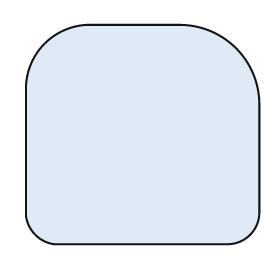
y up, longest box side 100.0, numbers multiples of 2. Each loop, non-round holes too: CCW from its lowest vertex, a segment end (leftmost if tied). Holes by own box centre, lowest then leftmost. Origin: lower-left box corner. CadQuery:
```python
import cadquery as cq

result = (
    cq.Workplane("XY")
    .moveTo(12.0, 0.0)
    .lineTo(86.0, 0.0)
    .threePointArc((96.0, 4.0), (100.0, 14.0))
    .lineTo(100.0, 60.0)
    .threePointArc((90.0, 84.0), (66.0, 94.0))
    .lineTo(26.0, 94.0)
    .threePointArc((8.0, 86.0), (0.0, 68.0))
    .lineTo(0.0, 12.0)
    .threePointArc((4.0, 4.0), (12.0, 0.0))
    .close()
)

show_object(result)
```